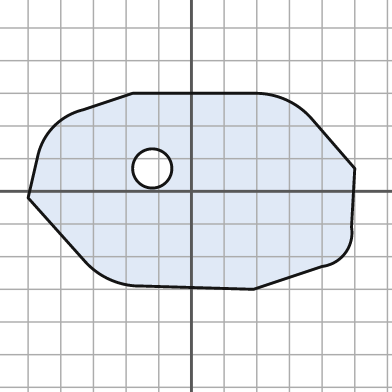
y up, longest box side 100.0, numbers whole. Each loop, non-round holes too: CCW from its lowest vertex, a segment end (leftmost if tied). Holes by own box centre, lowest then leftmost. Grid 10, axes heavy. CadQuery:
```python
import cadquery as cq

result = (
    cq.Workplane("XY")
    .moveTo(19.0, -30.0)
    .lineTo(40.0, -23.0)
    .threePointArc((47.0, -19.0), (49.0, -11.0))
    .lineTo(50.0, 7.0)
    .lineTo(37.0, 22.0)
    .threePointArc((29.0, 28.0), (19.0, 30.0))
    .lineTo(-18.0, 30.0)
    .lineTo(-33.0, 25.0)
    .threePointArc((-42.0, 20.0), (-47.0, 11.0))
    .lineTo(-50.0, -2.0)
    .lineTo(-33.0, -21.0)
    .threePointArc((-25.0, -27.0), (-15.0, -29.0))
    .close()
    .moveTo(-12.0, 7.0)
    .circle(6.0)
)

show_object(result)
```